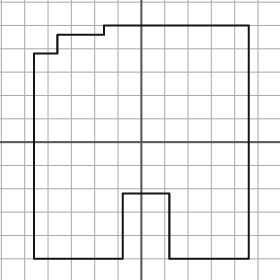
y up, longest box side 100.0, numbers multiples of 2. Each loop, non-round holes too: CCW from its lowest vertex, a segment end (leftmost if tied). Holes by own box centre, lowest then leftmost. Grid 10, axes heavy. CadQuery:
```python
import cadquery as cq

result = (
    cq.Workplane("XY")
    .moveTo(-46.0, -50.0)
    .lineTo(-8.0, -50.0)
    .lineTo(-8.0, -22.0)
    .lineTo(12.0, -22.0)
    .lineTo(12.0, -50.0)
    .lineTo(46.0, -50.0)
    .lineTo(46.0, 50.0)
    .lineTo(-16.0, 50.0)
    .lineTo(-16.0, 46.0)
    .lineTo(-36.0, 46.0)
    .lineTo(-36.0, 38.0)
    .lineTo(-46.0, 38.0)
    .close()
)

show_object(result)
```